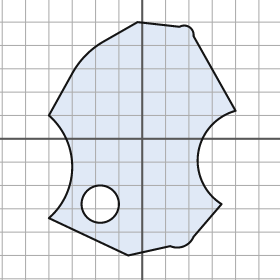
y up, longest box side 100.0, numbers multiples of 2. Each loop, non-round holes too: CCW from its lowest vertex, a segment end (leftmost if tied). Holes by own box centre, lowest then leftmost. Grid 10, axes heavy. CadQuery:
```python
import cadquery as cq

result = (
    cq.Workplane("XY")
    .moveTo(-6.0, -50.0)
    .lineTo(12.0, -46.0)
    .threePointArc((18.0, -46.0), (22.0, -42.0))
    .lineTo(34.0, -28.0)
    .threePointArc((24.0, -6.0), (40.0, 12.0))
    .lineTo(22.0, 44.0)
    .threePointArc((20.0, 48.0), (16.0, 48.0))
    .lineTo(-2.0, 50.0)
    .lineTo(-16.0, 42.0)
    .threePointArc((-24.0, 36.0), (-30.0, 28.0))
    .lineTo(-40.0, 10.0)
    .threePointArc((-30.0, -12.0), (-40.0, -34.0))
    .close()
    .moveTo(-18.0, -28.0)
    .circle(8.0)
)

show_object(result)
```